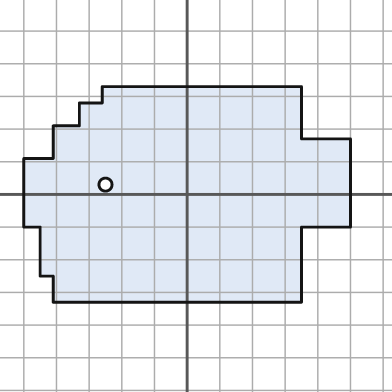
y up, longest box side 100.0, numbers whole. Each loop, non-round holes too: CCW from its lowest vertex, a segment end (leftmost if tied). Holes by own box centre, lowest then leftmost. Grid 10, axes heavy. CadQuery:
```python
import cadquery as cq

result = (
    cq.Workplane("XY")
    .moveTo(-41.0, -33.0)
    .lineTo(35.0, -33.0)
    .lineTo(35.0, -10.0)
    .lineTo(50.0, -10.0)
    .lineTo(50.0, 17.0)
    .lineTo(35.0, 17.0)
    .lineTo(35.0, 33.0)
    .lineTo(-26.0, 33.0)
    .lineTo(-26.0, 28.0)
    .lineTo(-33.0, 28.0)
    .lineTo(-33.0, 21.0)
    .lineTo(-41.0, 21.0)
    .lineTo(-41.0, 11.0)
    .lineTo(-50.0, 11.0)
    .lineTo(-50.0, -10.0)
    .lineTo(-45.0, -10.0)
    .lineTo(-45.0, -25.0)
    .lineTo(-41.0, -25.0)
    .close()
    .moveTo(-25.0, 3.0)
    .circle(2.0)
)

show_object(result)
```